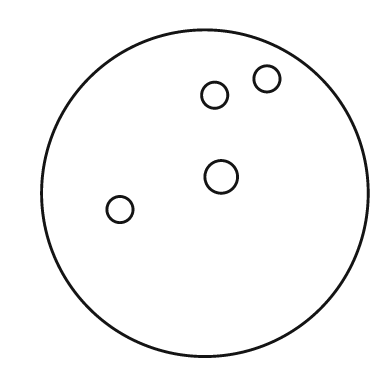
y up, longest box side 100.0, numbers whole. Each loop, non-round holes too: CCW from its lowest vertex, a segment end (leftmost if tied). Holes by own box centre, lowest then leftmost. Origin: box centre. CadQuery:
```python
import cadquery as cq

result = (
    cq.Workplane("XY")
    .moveTo(0.0, 0.0)
    .circle(50.0)
    .moveTo(-26.0, -5.0)
    .circle(4.0)
    .moveTo(5.0, 5.0)
    .circle(5.0)
    .moveTo(3.0, 30.0)
    .circle(4.0)
    .moveTo(19.0, 35.0)
    .circle(4.0)
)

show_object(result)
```